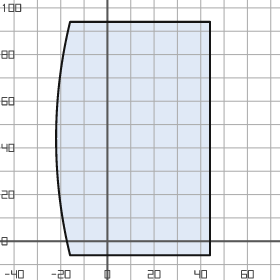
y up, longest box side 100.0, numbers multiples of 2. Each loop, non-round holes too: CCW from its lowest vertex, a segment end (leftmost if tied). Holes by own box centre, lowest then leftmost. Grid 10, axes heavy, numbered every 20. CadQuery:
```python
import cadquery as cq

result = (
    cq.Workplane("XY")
    .moveTo(-16.0, -6.0)
    .lineTo(44.0, -6.0)
    .lineTo(44.0, 94.0)
    .lineTo(-16.0, 94.0)
    .threePointArc((-22.0, 44.0), (-16.0, -6.0))
    .close()
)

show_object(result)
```